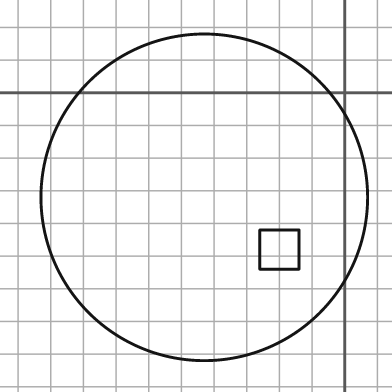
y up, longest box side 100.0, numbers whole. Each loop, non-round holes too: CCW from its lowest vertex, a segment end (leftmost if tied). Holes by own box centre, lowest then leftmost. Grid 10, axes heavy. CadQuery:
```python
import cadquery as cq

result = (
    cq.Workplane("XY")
    .moveTo(-43.0, -32.0)
    .circle(50.0)
    .moveTo(-26.0, -54.0)
    .lineTo(-14.0, -54.0)
    .lineTo(-14.0, -42.0)
    .lineTo(-26.0, -42.0)
    .close()
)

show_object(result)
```